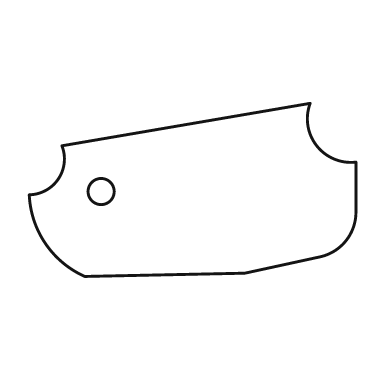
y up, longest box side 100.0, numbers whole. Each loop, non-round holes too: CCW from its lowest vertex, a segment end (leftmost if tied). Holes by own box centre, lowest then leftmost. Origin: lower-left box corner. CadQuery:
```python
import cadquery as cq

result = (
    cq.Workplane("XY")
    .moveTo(17.0, 0.0)
    .lineTo(66.0, 1.0)
    .lineTo(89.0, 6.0)
    .threePointArc((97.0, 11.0), (100.0, 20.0))
    .lineTo(100.0, 35.0)
    .threePointArc((88.0, 40.0), (86.0, 53.0))
    .lineTo(10.0, 40.0)
    .threePointArc((9.0, 30.0), (0.0, 25.0))
    .threePointArc((5.0, 10.0), (17.0, 0.0))
    .close()
    .moveTo(22.0, 26.0)
    .circle(4.0)
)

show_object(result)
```